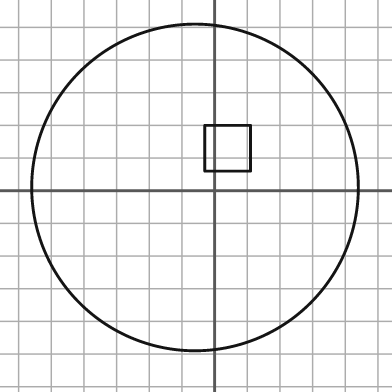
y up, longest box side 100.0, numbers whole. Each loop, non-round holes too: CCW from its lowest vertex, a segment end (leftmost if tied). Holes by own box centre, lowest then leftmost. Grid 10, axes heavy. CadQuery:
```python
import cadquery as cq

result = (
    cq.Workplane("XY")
    .moveTo(-6.0, 1.0)
    .circle(50.0)
    .moveTo(-3.0, 6.0)
    .lineTo(11.0, 6.0)
    .lineTo(11.0, 20.0)
    .lineTo(-3.0, 20.0)
    .close()
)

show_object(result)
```